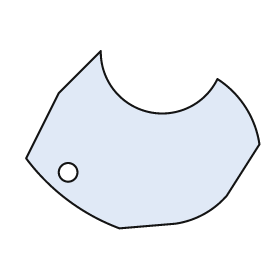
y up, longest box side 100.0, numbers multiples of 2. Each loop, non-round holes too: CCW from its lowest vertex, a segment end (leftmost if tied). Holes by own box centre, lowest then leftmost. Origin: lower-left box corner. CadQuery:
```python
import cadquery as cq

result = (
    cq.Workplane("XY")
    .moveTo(40.0, 0.0)
    .lineTo(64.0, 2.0)
    .threePointArc((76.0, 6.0), (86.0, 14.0))
    .lineTo(100.0, 36.0)
    .threePointArc((94.0, 52.0), (82.0, 64.0))
    .threePointArc((52.0, 50.0), (32.0, 76.0))
    .lineTo(14.0, 58.0)
    .lineTo(0.0, 30.0)
    .threePointArc((18.0, 12.0), (40.0, 0.0))
    .close()
    .moveTo(18.0, 24.0)
    .circle(4.0)
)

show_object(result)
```